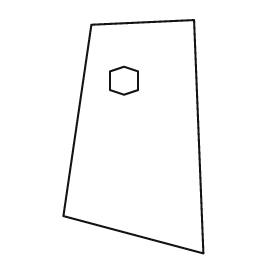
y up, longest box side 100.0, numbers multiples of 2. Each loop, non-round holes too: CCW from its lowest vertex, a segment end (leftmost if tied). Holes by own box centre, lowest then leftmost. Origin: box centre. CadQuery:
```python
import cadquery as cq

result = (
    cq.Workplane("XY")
    .moveTo(30.0, -50.0)
    .lineTo(26.0, 50.0)
    .lineTo(-18.0, 48.0)
    .lineTo(-30.0, -34.0)
    .close()
    .moveTo(-4.0, 18.0)
    .lineTo(2.0, 20.0)
    .lineTo(2.0, 28.0)
    .lineTo(-4.0, 30.0)
    .lineTo(-10.0, 28.0)
    .lineTo(-10.0, 20.0)
    .close()
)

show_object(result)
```